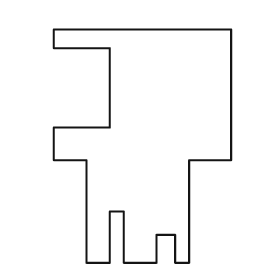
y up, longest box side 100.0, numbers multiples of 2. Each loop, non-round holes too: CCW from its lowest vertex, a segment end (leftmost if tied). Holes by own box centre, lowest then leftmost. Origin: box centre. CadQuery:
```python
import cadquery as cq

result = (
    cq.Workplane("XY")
    .moveTo(-24.0, -50.0)
    .lineTo(-14.0, -50.0)
    .lineTo(-14.0, -28.0)
    .lineTo(-8.0, -28.0)
    .lineTo(-8.0, -50.0)
    .lineTo(6.0, -50.0)
    .lineTo(6.0, -38.0)
    .lineTo(14.0, -38.0)
    .lineTo(14.0, -50.0)
    .lineTo(20.0, -50.0)
    .lineTo(20.0, -6.0)
    .lineTo(38.0, -6.0)
    .lineTo(38.0, 50.0)
    .lineTo(-38.0, 50.0)
    .lineTo(-38.0, 42.0)
    .lineTo(-14.0, 42.0)
    .lineTo(-14.0, 8.0)
    .lineTo(-38.0, 8.0)
    .lineTo(-38.0, -6.0)
    .lineTo(-24.0, -6.0)
    .close()
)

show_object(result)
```